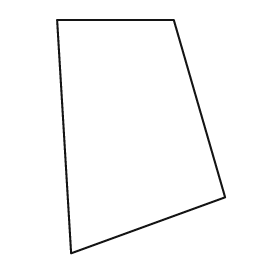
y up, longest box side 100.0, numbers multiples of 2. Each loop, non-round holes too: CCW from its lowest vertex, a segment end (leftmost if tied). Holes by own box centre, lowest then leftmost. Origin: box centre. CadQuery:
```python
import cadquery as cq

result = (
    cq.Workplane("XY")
    .moveTo(-30.0, -50.0)
    .lineTo(36.0, -26.0)
    .lineTo(14.0, 50.0)
    .lineTo(-36.0, 50.0)
    .close()
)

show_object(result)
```